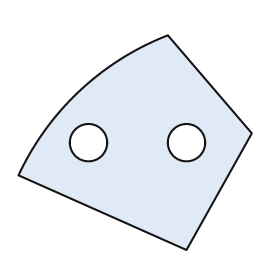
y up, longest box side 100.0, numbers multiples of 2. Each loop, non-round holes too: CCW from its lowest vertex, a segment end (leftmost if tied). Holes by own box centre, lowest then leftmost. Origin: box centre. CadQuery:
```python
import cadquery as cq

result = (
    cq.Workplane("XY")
    .moveTo(22.0, -46.0)
    .lineTo(50.0, 4.0)
    .lineTo(14.0, 46.0)
    .threePointArc((-24.0, 22.0), (-50.0, -14.0))
    .close()
    .moveTo(-20.0, 0.0)
    .circle(8.0)
    .moveTo(22.0, 0.0)
    .circle(8.0)
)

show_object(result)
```